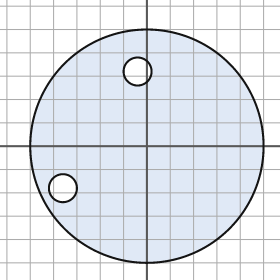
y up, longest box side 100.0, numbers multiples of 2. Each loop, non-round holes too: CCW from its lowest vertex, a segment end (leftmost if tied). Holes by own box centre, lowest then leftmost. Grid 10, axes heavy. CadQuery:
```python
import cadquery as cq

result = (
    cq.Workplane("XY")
    .moveTo(0.0, 0.0)
    .circle(50.0)
    .moveTo(-36.0, -18.0)
    .circle(6.0)
    .moveTo(-4.0, 32.0)
    .circle(6.0)
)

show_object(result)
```